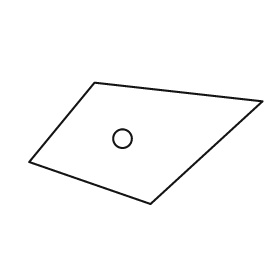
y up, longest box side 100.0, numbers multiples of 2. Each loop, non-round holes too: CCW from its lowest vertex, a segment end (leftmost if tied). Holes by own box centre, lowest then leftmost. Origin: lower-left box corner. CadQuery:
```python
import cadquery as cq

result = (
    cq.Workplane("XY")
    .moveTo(52.0, 0.0)
    .lineTo(100.0, 44.0)
    .lineTo(28.0, 52.0)
    .lineTo(0.0, 18.0)
    .close()
    .moveTo(40.0, 28.0)
    .circle(4.0)
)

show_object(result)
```